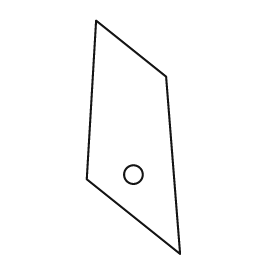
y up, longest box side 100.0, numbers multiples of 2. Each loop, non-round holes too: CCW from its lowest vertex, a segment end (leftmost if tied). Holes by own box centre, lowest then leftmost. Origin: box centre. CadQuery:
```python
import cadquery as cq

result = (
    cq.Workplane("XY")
    .moveTo(20.0, -50.0)
    .lineTo(14.0, 26.0)
    .lineTo(-16.0, 50.0)
    .lineTo(-20.0, -18.0)
    .close()
    .moveTo(0.0, -16.0)
    .circle(4.0)
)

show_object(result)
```